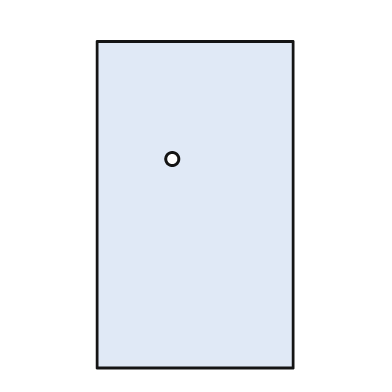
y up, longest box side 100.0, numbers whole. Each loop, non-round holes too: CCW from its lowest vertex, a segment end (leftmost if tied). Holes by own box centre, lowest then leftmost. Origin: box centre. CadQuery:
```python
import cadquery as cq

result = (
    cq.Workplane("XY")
    .moveTo(-30.0, -50.0)
    .lineTo(30.0, -50.0)
    .lineTo(30.0, 50.0)
    .lineTo(-30.0, 50.0)
    .close()
    .moveTo(-7.0, 14.0)
    .circle(2.0)
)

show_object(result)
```